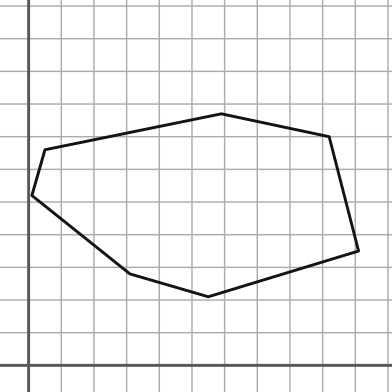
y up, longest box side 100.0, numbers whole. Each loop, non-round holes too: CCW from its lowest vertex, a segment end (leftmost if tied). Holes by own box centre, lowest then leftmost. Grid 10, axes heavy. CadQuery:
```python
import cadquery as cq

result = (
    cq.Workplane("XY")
    .moveTo(55.0, 21.0)
    .lineTo(101.0, 35.0)
    .lineTo(92.0, 70.0)
    .lineTo(59.0, 77.0)
    .lineTo(5.0, 66.0)
    .lineTo(1.0, 52.0)
    .lineTo(31.0, 28.0)
    .close()
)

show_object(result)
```